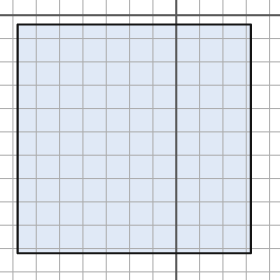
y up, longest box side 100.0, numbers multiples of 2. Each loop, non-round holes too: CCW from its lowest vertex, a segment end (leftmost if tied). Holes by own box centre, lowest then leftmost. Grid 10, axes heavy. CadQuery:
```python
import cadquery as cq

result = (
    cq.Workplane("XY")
    .moveTo(-68.0, -102.0)
    .lineTo(32.0, -102.0)
    .lineTo(32.0, -4.0)
    .lineTo(-68.0, -4.0)
    .close()
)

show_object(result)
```